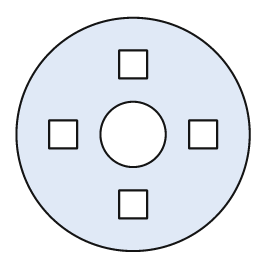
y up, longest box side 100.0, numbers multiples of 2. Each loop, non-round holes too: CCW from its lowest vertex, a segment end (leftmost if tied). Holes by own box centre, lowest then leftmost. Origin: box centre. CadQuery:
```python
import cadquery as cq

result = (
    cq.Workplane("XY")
    .moveTo(0.0, 0.0)
    .circle(50.0)
    .moveTo(-6.0, -36.0)
    .lineTo(6.0, -36.0)
    .lineTo(6.0, -24.0)
    .lineTo(-6.0, -24.0)
    .close()
    .moveTo(-36.0, -6.0)
    .lineTo(-24.0, -6.0)
    .lineTo(-24.0, 6.0)
    .lineTo(-36.0, 6.0)
    .close()
    .moveTo(0.0, 0.0)
    .circle(14.0)
    .moveTo(24.0, -6.0)
    .lineTo(36.0, -6.0)
    .lineTo(36.0, 6.0)
    .lineTo(24.0, 6.0)
    .close()
    .moveTo(-6.0, 24.0)
    .lineTo(6.0, 24.0)
    .lineTo(6.0, 36.0)
    .lineTo(-6.0, 36.0)
    .close()
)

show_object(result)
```